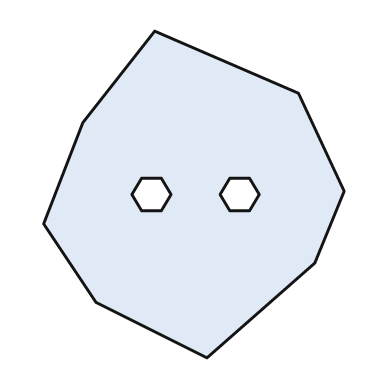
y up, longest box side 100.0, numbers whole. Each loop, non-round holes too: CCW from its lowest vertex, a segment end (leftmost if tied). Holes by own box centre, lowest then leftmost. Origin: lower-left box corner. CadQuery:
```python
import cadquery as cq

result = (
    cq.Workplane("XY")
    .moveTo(50.0, 0.0)
    .lineTo(83.0, 29.0)
    .lineTo(92.0, 51.0)
    .lineTo(78.0, 81.0)
    .lineTo(34.0, 100.0)
    .lineTo(12.0, 72.0)
    .lineTo(0.0, 41.0)
    .lineTo(16.0, 17.0)
    .close()
    .moveTo(30.0, 45.0)
    .lineTo(36.0, 45.0)
    .lineTo(39.0, 50.0)
    .lineTo(36.0, 55.0)
    .lineTo(30.0, 55.0)
    .lineTo(27.0, 50.0)
    .close()
    .moveTo(57.0, 45.0)
    .lineTo(63.0, 45.0)
    .lineTo(66.0, 50.0)
    .lineTo(63.0, 55.0)
    .lineTo(57.0, 55.0)
    .lineTo(54.0, 50.0)
    .close()
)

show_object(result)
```